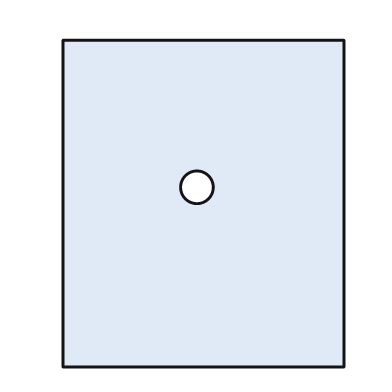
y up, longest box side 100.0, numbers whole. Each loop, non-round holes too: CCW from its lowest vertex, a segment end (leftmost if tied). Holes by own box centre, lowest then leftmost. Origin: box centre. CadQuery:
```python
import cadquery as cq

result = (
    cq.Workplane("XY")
    .moveTo(-43.0, -50.0)
    .lineTo(43.0, -50.0)
    .lineTo(43.0, 50.0)
    .lineTo(-43.0, 50.0)
    .close()
    .moveTo(-2.0, 5.0)
    .circle(5.0)
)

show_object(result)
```